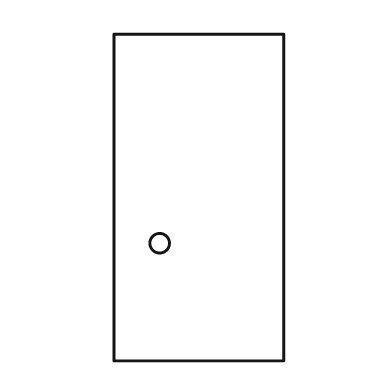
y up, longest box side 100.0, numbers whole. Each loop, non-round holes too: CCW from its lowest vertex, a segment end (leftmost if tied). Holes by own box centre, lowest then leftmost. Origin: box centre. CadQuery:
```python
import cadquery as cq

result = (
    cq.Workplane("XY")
    .moveTo(-26.0, -50.0)
    .lineTo(26.0, -50.0)
    .lineTo(26.0, 50.0)
    .lineTo(-26.0, 50.0)
    .close()
    .moveTo(-12.0, -14.0)
    .circle(3.0)
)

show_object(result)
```